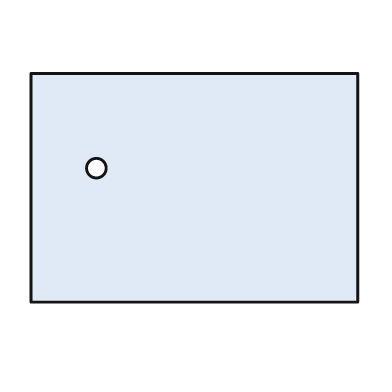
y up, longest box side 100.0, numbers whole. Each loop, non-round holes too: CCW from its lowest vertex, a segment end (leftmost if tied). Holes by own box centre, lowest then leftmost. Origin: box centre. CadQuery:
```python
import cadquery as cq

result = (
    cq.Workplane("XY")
    .moveTo(-50.0, -35.0)
    .lineTo(50.0, -35.0)
    .lineTo(50.0, 35.0)
    .lineTo(-50.0, 35.0)
    .close()
    .moveTo(-30.0, 6.0)
    .circle(3.0)
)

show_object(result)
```